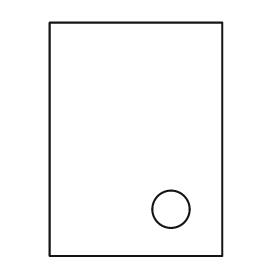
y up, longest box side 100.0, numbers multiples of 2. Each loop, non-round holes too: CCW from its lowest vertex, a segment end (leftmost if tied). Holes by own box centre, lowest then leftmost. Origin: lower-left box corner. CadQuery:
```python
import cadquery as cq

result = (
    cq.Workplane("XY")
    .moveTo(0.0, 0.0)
    .lineTo(74.0, 0.0)
    .lineTo(74.0, 100.0)
    .lineTo(0.0, 100.0)
    .close()
    .moveTo(52.0, 20.0)
    .circle(8.0)
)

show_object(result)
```